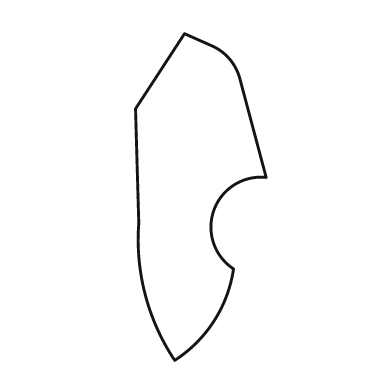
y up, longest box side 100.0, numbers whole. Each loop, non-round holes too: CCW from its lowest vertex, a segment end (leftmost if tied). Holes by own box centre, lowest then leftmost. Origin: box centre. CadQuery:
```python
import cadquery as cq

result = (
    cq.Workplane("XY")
    .moveTo(-8.0, -50.0)
    .threePointArc((4.0, -38.0), (10.0, -22.0))
    .threePointArc((4.0, -4.0), (20.0, 6.0))
    .lineTo(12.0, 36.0)
    .threePointArc((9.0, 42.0), (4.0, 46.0))
    .lineTo(-5.0, 50.0)
    .lineTo(-20.0, 27.0)
    .lineTo(-19.0, -8.0)
    .threePointArc((-17.0, -30.0), (-8.0, -50.0))
    .close()
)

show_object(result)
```